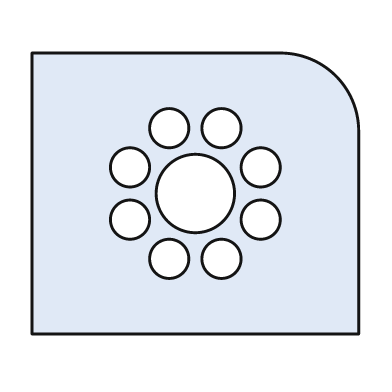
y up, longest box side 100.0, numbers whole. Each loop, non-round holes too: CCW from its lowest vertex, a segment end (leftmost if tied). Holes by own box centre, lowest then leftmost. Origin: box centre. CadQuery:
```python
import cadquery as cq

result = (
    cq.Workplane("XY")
    .moveTo(-50.0, -43.0)
    .lineTo(50.0, -43.0)
    .lineTo(50.0, 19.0)
    .threePointArc((43.0, 36.0), (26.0, 43.0))
    .lineTo(-50.0, 43.0)
    .close()
    .moveTo(-8.0, -20.0)
    .circle(6.0)
    .moveTo(8.0, -20.0)
    .circle(6.0)
    .moveTo(-20.0, -8.0)
    .circle(6.0)
    .moveTo(20.0, -8.0)
    .circle(6.0)
    .moveTo(0.0, 0.0)
    .circle(12.0)
    .moveTo(-20.0, 8.0)
    .circle(6.0)
    .moveTo(20.0, 8.0)
    .circle(6.0)
    .moveTo(-8.0, 20.0)
    .circle(6.0)
    .moveTo(8.0, 20.0)
    .circle(6.0)
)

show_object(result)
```